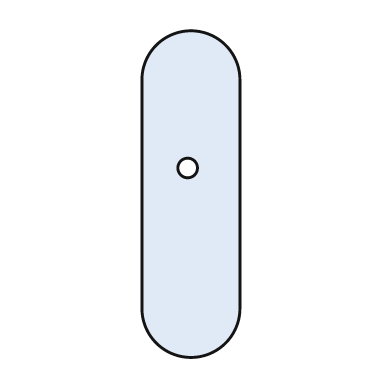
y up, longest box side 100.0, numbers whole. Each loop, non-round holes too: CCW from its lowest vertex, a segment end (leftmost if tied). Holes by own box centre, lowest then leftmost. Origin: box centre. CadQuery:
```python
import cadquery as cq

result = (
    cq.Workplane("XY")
    .moveTo(-15.0, -35.0)
    .threePointArc((0.0, -50.0), (15.0, -35.0))
    .lineTo(15.0, 35.0)
    .threePointArc((0.0, 50.0), (-15.0, 35.0))
    .close()
    .moveTo(-1.0, 8.0)
    .circle(3.0)
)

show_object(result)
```